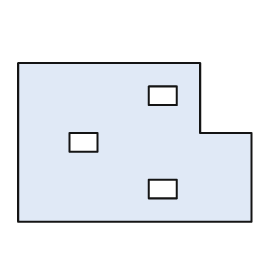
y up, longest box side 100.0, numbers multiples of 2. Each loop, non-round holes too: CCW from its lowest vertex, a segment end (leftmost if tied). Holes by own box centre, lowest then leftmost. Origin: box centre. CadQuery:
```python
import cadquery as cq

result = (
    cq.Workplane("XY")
    .moveTo(-50.0, -34.0)
    .lineTo(50.0, -34.0)
    .lineTo(50.0, 4.0)
    .lineTo(28.0, 4.0)
    .lineTo(28.0, 34.0)
    .lineTo(-50.0, 34.0)
    .close()
    .moveTo(6.0, -24.0)
    .lineTo(18.0, -24.0)
    .lineTo(18.0, -16.0)
    .lineTo(6.0, -16.0)
    .close()
    .moveTo(-28.0, -4.0)
    .lineTo(-16.0, -4.0)
    .lineTo(-16.0, 4.0)
    .lineTo(-28.0, 4.0)
    .close()
    .moveTo(6.0, 16.0)
    .lineTo(18.0, 16.0)
    .lineTo(18.0, 24.0)
    .lineTo(6.0, 24.0)
    .close()
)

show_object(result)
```